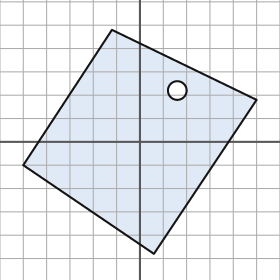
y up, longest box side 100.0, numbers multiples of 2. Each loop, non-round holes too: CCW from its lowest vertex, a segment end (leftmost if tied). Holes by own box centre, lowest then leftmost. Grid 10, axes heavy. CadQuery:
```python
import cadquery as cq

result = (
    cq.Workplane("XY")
    .moveTo(6.0, -48.0)
    .lineTo(50.0, 18.0)
    .lineTo(-12.0, 48.0)
    .lineTo(-50.0, -10.0)
    .close()
    .moveTo(16.0, 22.0)
    .circle(4.0)
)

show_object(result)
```